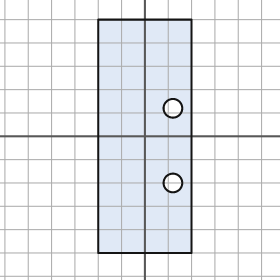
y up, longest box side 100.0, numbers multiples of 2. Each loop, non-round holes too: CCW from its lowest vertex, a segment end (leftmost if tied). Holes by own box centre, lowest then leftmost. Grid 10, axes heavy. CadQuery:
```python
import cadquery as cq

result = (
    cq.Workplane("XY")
    .moveTo(-20.0, -50.0)
    .lineTo(20.0, -50.0)
    .lineTo(20.0, 50.0)
    .lineTo(-20.0, 50.0)
    .close()
    .moveTo(12.0, -20.0)
    .circle(4.0)
    .moveTo(12.0, 12.0)
    .circle(4.0)
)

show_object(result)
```